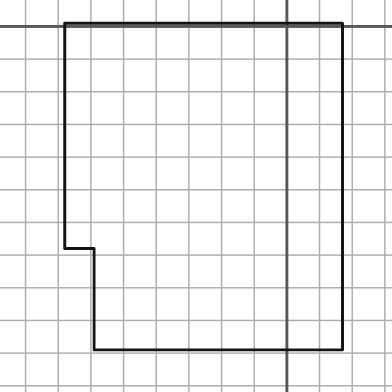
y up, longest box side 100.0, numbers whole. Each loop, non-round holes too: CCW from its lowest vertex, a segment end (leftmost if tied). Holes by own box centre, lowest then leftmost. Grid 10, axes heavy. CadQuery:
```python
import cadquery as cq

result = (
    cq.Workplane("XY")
    .moveTo(-59.0, -99.0)
    .lineTo(17.0, -99.0)
    .lineTo(17.0, 1.0)
    .lineTo(-68.0, 1.0)
    .lineTo(-68.0, -68.0)
    .lineTo(-59.0, -68.0)
    .close()
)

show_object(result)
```